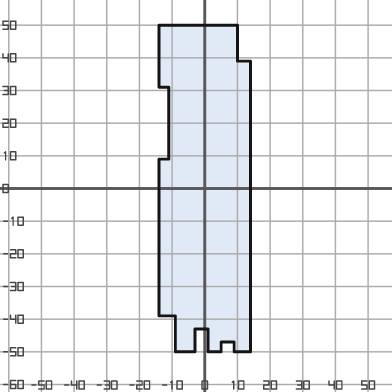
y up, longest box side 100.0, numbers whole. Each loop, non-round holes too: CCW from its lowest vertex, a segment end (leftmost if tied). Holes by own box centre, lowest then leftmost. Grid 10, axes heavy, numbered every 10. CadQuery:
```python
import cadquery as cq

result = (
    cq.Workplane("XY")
    .moveTo(-9.0, -50.0)
    .lineTo(-3.0, -50.0)
    .lineTo(-3.0, -43.0)
    .lineTo(1.0, -43.0)
    .lineTo(1.0, -50.0)
    .lineTo(5.0, -50.0)
    .lineTo(5.0, -47.0)
    .lineTo(9.0, -47.0)
    .lineTo(9.0, -50.0)
    .lineTo(14.0, -50.0)
    .lineTo(14.0, 39.0)
    .lineTo(10.0, 39.0)
    .lineTo(10.0, 50.0)
    .lineTo(-14.0, 50.0)
    .lineTo(-14.0, 31.0)
    .lineTo(-11.0, 31.0)
    .lineTo(-11.0, 9.0)
    .lineTo(-14.0, 9.0)
    .lineTo(-14.0, -39.0)
    .lineTo(-9.0, -39.0)
    .close()
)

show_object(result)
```